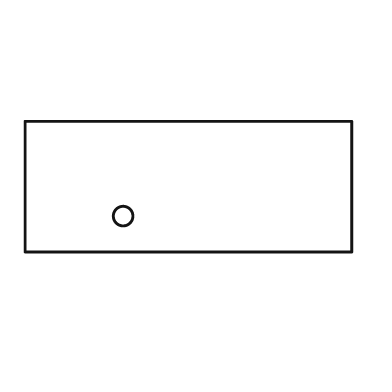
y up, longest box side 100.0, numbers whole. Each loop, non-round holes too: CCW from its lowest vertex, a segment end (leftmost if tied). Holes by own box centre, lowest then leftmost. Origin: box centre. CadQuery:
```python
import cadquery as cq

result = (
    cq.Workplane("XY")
    .moveTo(-50.0, -20.0)
    .lineTo(50.0, -20.0)
    .lineTo(50.0, 20.0)
    .lineTo(-50.0, 20.0)
    .close()
    .moveTo(-20.0, -9.0)
    .circle(3.0)
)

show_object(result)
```